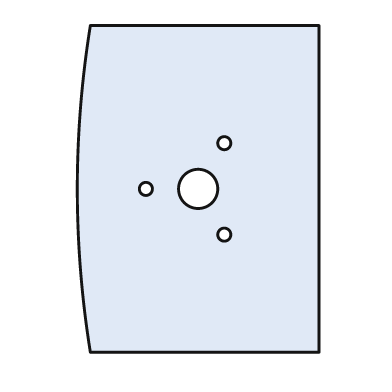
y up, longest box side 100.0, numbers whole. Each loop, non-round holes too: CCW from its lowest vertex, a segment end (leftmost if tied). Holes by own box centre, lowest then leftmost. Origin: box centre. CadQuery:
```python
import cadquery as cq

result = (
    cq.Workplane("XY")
    .moveTo(-33.0, -50.0)
    .lineTo(37.0, -50.0)
    .lineTo(37.0, 50.0)
    .lineTo(-33.0, 50.0)
    .threePointArc((-37.0, 0.0), (-33.0, -50.0))
    .close()
    .moveTo(8.0, -14.0)
    .circle(2.0)
    .moveTo(-16.0, 0.0)
    .circle(2.0)
    .moveTo(0.0, 0.0)
    .circle(6.0)
    .moveTo(8.0, 14.0)
    .circle(2.0)
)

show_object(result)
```